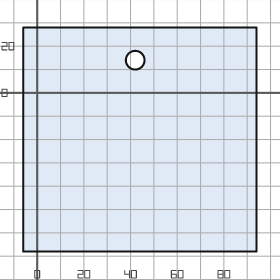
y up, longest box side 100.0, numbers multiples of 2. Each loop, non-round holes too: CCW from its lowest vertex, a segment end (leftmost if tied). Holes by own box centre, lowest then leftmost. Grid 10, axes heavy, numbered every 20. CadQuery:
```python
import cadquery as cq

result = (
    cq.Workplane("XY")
    .moveTo(-6.0, -68.0)
    .lineTo(94.0, -68.0)
    .lineTo(94.0, 28.0)
    .lineTo(-6.0, 28.0)
    .close()
    .moveTo(42.0, 14.0)
    .circle(4.0)
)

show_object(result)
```